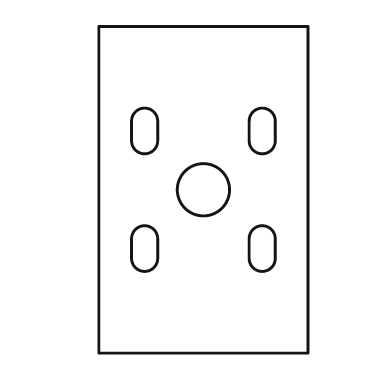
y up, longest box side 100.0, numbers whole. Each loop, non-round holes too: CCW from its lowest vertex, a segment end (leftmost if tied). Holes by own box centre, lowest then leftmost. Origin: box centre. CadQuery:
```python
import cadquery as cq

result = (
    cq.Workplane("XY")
    .moveTo(-32.0, -50.0)
    .lineTo(32.0, -50.0)
    .lineTo(32.0, 50.0)
    .lineTo(-32.0, 50.0)
    .close()
    .moveTo(-22.0, -21.0)
    .threePointArc((-18.0, -25.0), (-14.0, -21.0))
    .lineTo(-14.0, -15.0)
    .threePointArc((-18.0, -11.0), (-22.0, -15.0))
    .close()
    .moveTo(14.0, -21.0)
    .threePointArc((18.0, -25.0), (22.0, -21.0))
    .lineTo(22.0, -15.0)
    .threePointArc((18.0, -11.0), (14.0, -15.0))
    .close()
    .moveTo(0.0, 0.0)
    .circle(8.0)
    .moveTo(-22.0, 15.0)
    .threePointArc((-18.0, 11.0), (-14.0, 15.0))
    .lineTo(-14.0, 21.0)
    .threePointArc((-18.0, 25.0), (-22.0, 21.0))
    .close()
    .moveTo(14.0, 15.0)
    .threePointArc((18.0, 11.0), (22.0, 15.0))
    .lineTo(22.0, 21.0)
    .threePointArc((18.0, 25.0), (14.0, 21.0))
    .close()
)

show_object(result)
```